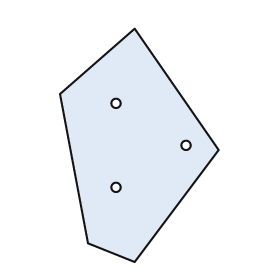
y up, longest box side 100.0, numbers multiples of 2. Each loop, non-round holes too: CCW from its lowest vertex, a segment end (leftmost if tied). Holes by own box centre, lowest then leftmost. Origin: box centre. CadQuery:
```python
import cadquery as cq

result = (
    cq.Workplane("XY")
    .moveTo(-2.0, -50.0)
    .lineTo(34.0, -2.0)
    .lineTo(-2.0, 50.0)
    .lineTo(-34.0, 22.0)
    .lineTo(-22.0, -42.0)
    .close()
    .moveTo(-10.0, -18.0)
    .circle(2.0)
    .moveTo(20.0, 0.0)
    .circle(2.0)
    .moveTo(-10.0, 18.0)
    .circle(2.0)
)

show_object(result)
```